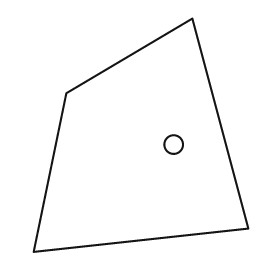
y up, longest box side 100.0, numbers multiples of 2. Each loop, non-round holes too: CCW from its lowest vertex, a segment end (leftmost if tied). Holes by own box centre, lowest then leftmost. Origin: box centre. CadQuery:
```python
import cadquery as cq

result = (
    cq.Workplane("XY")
    .moveTo(-46.0, -50.0)
    .lineTo(46.0, -40.0)
    .lineTo(22.0, 50.0)
    .lineTo(-32.0, 18.0)
    .close()
    .moveTo(14.0, -4.0)
    .circle(4.0)
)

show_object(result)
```